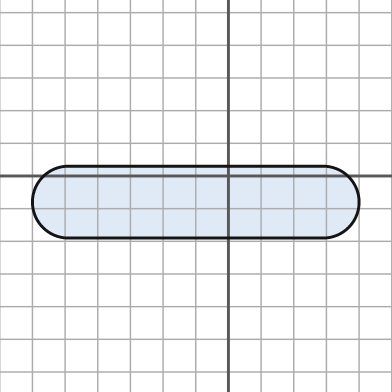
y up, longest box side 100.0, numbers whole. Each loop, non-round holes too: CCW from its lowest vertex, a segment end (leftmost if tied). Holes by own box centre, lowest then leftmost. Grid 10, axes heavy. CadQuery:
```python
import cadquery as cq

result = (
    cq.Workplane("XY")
    .moveTo(-49.0, -19.0)
    .lineTo(29.0, -19.0)
    .threePointArc((40.0, -8.0), (29.0, 3.0))
    .lineTo(-49.0, 3.0)
    .threePointArc((-60.0, -8.0), (-49.0, -19.0))
    .close()
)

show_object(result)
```